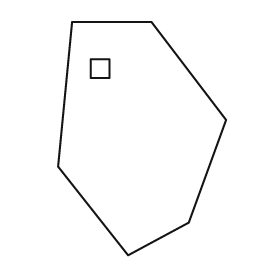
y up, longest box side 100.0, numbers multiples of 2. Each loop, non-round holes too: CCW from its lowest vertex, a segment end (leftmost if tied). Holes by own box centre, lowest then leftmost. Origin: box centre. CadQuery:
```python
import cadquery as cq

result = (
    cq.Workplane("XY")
    .moveTo(-6.0, -50.0)
    .lineTo(20.0, -36.0)
    .lineTo(36.0, 8.0)
    .lineTo(4.0, 50.0)
    .lineTo(-30.0, 50.0)
    .lineTo(-36.0, -12.0)
    .close()
    .moveTo(-22.0, 26.0)
    .lineTo(-14.0, 26.0)
    .lineTo(-14.0, 34.0)
    .lineTo(-22.0, 34.0)
    .close()
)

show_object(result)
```